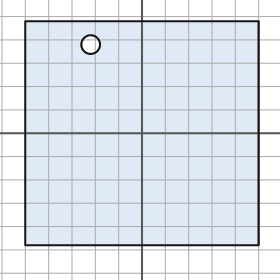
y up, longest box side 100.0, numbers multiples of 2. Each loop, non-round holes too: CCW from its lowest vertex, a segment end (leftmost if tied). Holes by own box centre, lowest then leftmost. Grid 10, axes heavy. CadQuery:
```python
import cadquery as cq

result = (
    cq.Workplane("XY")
    .moveTo(-50.0, -48.0)
    .lineTo(50.0, -48.0)
    .lineTo(50.0, 48.0)
    .lineTo(-50.0, 48.0)
    .close()
    .moveTo(-22.0, 38.0)
    .circle(4.0)
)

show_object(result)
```